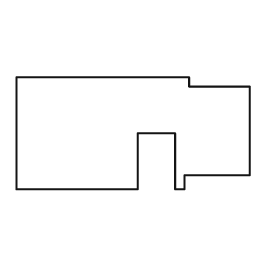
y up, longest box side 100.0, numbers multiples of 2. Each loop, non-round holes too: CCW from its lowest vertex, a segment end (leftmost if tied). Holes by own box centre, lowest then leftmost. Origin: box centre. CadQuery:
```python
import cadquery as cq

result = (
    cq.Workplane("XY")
    .moveTo(-50.0, -24.0)
    .lineTo(2.0, -24.0)
    .lineTo(2.0, 0.0)
    .lineTo(18.0, 0.0)
    .lineTo(18.0, -24.0)
    .lineTo(22.0, -24.0)
    .lineTo(22.0, -18.0)
    .lineTo(50.0, -18.0)
    .lineTo(50.0, 20.0)
    .lineTo(24.0, 20.0)
    .lineTo(24.0, 24.0)
    .lineTo(-50.0, 24.0)
    .close()
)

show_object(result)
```